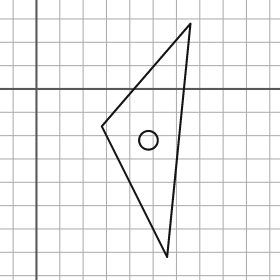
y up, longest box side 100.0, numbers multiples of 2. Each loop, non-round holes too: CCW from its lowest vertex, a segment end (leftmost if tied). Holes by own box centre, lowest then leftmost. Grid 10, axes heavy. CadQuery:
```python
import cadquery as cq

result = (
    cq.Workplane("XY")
    .moveTo(56.0, -72.0)
    .lineTo(66.0, 28.0)
    .lineTo(28.0, -16.0)
    .close()
    .moveTo(48.0, -22.0)
    .circle(4.0)
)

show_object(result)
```